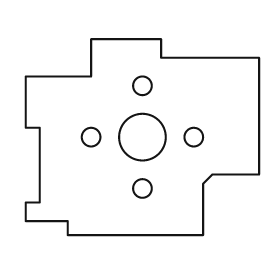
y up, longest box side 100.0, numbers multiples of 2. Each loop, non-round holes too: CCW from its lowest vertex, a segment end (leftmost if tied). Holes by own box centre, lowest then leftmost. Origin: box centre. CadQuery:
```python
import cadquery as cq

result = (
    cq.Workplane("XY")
    .moveTo(-32.0, -42.0)
    .lineTo(26.0, -42.0)
    .lineTo(26.0, -20.0)
    .lineTo(30.0, -16.0)
    .lineTo(50.0, -16.0)
    .lineTo(50.0, 34.0)
    .lineTo(8.0, 34.0)
    .lineTo(8.0, 42.0)
    .lineTo(-22.0, 42.0)
    .lineTo(-22.0, 26.0)
    .lineTo(-50.0, 26.0)
    .lineTo(-50.0, 4.0)
    .lineTo(-44.0, 4.0)
    .lineTo(-44.0, -28.0)
    .lineTo(-50.0, -28.0)
    .lineTo(-50.0, -36.0)
    .lineTo(-32.0, -36.0)
    .close()
    .moveTo(0.0, -22.0)
    .circle(4.0)
    .moveTo(-22.0, 0.0)
    .circle(4.0)
    .moveTo(0.0, 0.0)
    .circle(10.0)
    .moveTo(22.0, 0.0)
    .circle(4.0)
    .moveTo(0.0, 22.0)
    .circle(4.0)
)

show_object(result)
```